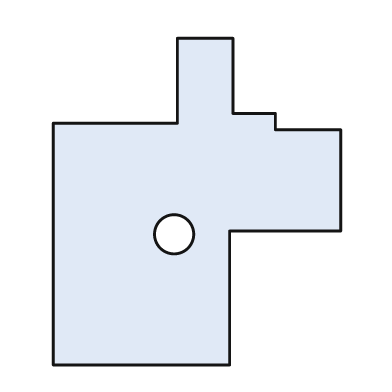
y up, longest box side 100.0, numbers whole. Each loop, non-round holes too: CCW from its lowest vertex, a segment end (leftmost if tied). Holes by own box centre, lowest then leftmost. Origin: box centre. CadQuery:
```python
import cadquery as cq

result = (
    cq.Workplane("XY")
    .moveTo(-44.0, -50.0)
    .lineTo(10.0, -50.0)
    .lineTo(10.0, -9.0)
    .lineTo(44.0, -9.0)
    .lineTo(44.0, 22.0)
    .lineTo(24.0, 22.0)
    .lineTo(24.0, 27.0)
    .lineTo(11.0, 27.0)
    .lineTo(11.0, 50.0)
    .lineTo(-6.0, 50.0)
    .lineTo(-6.0, 24.0)
    .lineTo(-44.0, 24.0)
    .close()
    .moveTo(-7.0, -10.0)
    .circle(6.0)
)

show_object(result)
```